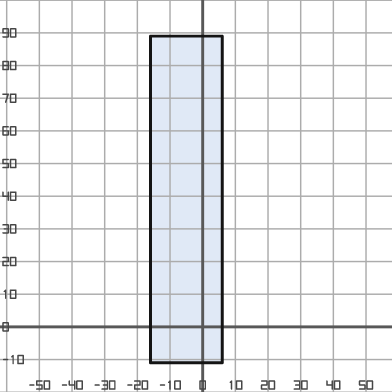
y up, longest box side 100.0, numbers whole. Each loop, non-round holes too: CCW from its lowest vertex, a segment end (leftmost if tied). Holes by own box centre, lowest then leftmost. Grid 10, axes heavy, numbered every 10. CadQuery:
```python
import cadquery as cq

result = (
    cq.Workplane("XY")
    .moveTo(-16.0, -11.0)
    .lineTo(6.0, -11.0)
    .lineTo(6.0, 89.0)
    .lineTo(-16.0, 89.0)
    .close()
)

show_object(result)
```